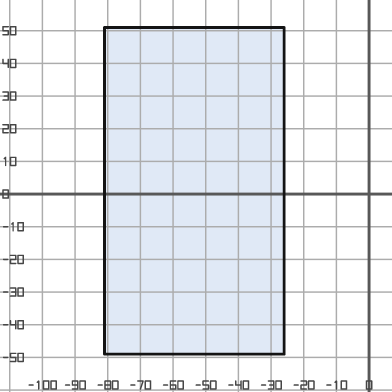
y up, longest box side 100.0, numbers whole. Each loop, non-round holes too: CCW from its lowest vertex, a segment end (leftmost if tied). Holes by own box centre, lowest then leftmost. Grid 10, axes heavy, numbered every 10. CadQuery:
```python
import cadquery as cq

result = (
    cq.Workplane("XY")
    .moveTo(-81.0, -49.0)
    .lineTo(-26.0, -49.0)
    .lineTo(-26.0, 51.0)
    .lineTo(-81.0, 51.0)
    .close()
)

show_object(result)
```